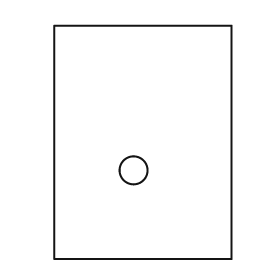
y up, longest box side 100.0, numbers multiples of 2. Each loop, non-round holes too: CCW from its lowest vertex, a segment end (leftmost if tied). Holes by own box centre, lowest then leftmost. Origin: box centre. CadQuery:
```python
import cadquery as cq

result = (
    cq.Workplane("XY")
    .moveTo(-38.0, -50.0)
    .lineTo(38.0, -50.0)
    .lineTo(38.0, 50.0)
    .lineTo(-38.0, 50.0)
    .close()
    .moveTo(-4.0, -12.0)
    .circle(6.0)
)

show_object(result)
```